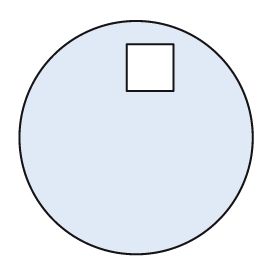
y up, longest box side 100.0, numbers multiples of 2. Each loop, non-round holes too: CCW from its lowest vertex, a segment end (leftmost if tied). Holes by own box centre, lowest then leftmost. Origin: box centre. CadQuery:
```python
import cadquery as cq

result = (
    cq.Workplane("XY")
    .moveTo(0.0, 0.0)
    .circle(50.0)
    .moveTo(-4.0, 20.0)
    .lineTo(16.0, 20.0)
    .lineTo(16.0, 40.0)
    .lineTo(-4.0, 40.0)
    .close()
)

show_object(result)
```